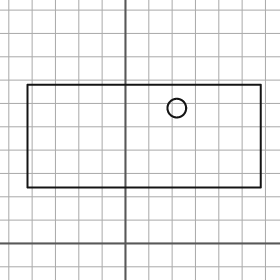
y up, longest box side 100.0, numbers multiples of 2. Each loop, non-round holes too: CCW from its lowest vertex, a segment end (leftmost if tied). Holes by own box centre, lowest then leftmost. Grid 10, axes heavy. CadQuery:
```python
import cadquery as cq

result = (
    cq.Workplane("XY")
    .moveTo(-42.0, 24.0)
    .lineTo(58.0, 24.0)
    .lineTo(58.0, 68.0)
    .lineTo(-42.0, 68.0)
    .close()
    .moveTo(22.0, 58.0)
    .circle(4.0)
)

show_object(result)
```